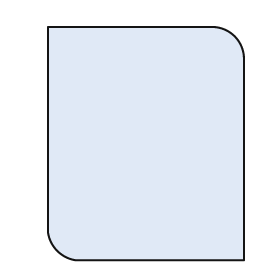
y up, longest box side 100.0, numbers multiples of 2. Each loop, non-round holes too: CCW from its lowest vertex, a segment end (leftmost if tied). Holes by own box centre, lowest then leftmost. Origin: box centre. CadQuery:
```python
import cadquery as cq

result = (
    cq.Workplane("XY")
    .moveTo(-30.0, -50.0)
    .lineTo(42.0, -50.0)
    .lineTo(42.0, 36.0)
    .threePointArc((38.0, 46.0), (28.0, 50.0))
    .lineTo(-42.0, 50.0)
    .lineTo(-42.0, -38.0)
    .threePointArc((-38.0, -46.0), (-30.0, -50.0))
    .close()
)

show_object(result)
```